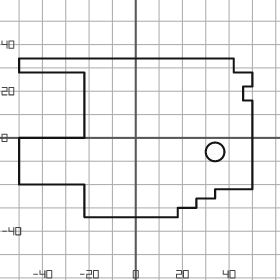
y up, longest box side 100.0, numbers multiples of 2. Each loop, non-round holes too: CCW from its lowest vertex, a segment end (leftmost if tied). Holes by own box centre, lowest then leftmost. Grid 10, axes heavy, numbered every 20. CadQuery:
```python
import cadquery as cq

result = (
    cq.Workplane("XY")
    .moveTo(-22.0, -34.0)
    .lineTo(18.0, -34.0)
    .lineTo(18.0, -30.0)
    .lineTo(26.0, -30.0)
    .lineTo(26.0, -26.0)
    .lineTo(34.0, -26.0)
    .lineTo(34.0, -22.0)
    .lineTo(50.0, -22.0)
    .lineTo(50.0, 16.0)
    .lineTo(46.0, 16.0)
    .lineTo(46.0, 22.0)
    .lineTo(50.0, 22.0)
    .lineTo(50.0, 28.0)
    .lineTo(42.0, 28.0)
    .lineTo(42.0, 34.0)
    .lineTo(-50.0, 34.0)
    .lineTo(-50.0, 28.0)
    .lineTo(-22.0, 28.0)
    .lineTo(-22.0, 0.0)
    .lineTo(-50.0, 0.0)
    .lineTo(-50.0, -20.0)
    .lineTo(-22.0, -20.0)
    .close()
    .moveTo(34.0, -6.0)
    .circle(4.0)
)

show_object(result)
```